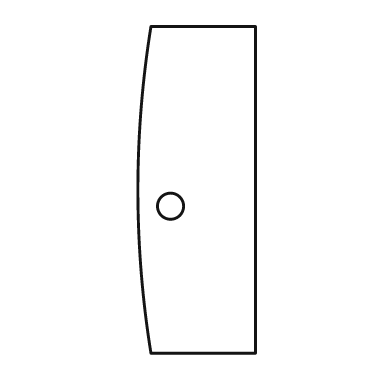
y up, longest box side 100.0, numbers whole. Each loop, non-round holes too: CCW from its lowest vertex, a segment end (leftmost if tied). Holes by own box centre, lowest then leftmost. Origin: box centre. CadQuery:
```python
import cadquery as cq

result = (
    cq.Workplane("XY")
    .moveTo(-14.0, -50.0)
    .lineTo(18.0, -50.0)
    .lineTo(18.0, 50.0)
    .lineTo(-14.0, 50.0)
    .threePointArc((-18.0, 0.0), (-14.0, -50.0))
    .close()
    .moveTo(-8.0, -5.0)
    .circle(4.0)
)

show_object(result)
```